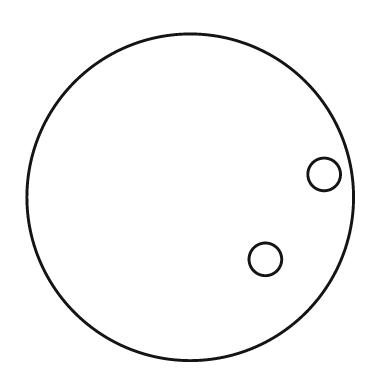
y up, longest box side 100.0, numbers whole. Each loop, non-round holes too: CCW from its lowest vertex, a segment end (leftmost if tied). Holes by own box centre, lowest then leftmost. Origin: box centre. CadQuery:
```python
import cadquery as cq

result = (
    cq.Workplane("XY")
    .moveTo(0.0, 0.0)
    .circle(50.0)
    .moveTo(23.0, -19.0)
    .circle(5.0)
    .moveTo(41.0, 7.0)
    .circle(5.0)
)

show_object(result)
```